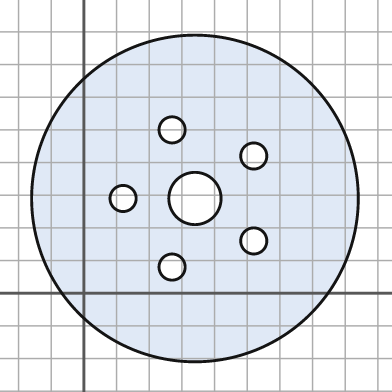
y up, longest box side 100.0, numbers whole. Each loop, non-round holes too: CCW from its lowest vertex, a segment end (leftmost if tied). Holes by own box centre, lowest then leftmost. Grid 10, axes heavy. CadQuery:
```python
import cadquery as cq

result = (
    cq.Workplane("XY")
    .moveTo(34.0, 29.0)
    .circle(50.0)
    .moveTo(27.0, 8.0)
    .circle(4.0)
    .moveTo(52.0, 16.0)
    .circle(4.0)
    .moveTo(12.0, 29.0)
    .circle(4.0)
    .moveTo(34.0, 29.0)
    .circle(8.0)
    .moveTo(52.0, 42.0)
    .circle(4.0)
    .moveTo(27.0, 50.0)
    .circle(4.0)
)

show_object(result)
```